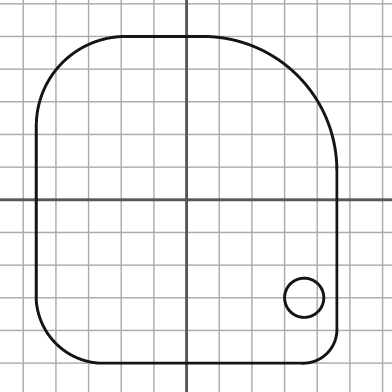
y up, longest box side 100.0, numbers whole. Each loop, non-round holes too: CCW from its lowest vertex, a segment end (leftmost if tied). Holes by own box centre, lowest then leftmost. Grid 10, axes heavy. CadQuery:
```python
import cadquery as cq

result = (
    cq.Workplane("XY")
    .moveTo(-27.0, -50.0)
    .lineTo(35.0, -50.0)
    .threePointArc((43.0, -47.0), (46.0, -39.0))
    .lineTo(46.0, 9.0)
    .threePointArc((34.0, 38.0), (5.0, 50.0))
    .lineTo(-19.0, 50.0)
    .threePointArc((-38.0, 42.0), (-46.0, 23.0))
    .lineTo(-46.0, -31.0)
    .threePointArc((-40.0, -44.0), (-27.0, -50.0))
    .close()
    .moveTo(36.0, -30.0)
    .circle(6.0)
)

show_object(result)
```